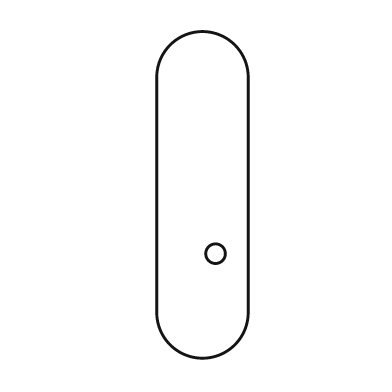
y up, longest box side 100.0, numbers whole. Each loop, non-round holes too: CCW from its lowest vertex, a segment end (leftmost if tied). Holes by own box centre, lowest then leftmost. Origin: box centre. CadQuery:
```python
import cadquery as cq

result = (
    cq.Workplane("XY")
    .moveTo(-14.0, -36.0)
    .threePointArc((0.0, -50.0), (14.0, -36.0))
    .lineTo(14.0, 36.0)
    .threePointArc((0.0, 50.0), (-14.0, 36.0))
    .close()
    .moveTo(4.0, -18.0)
    .circle(3.0)
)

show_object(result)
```